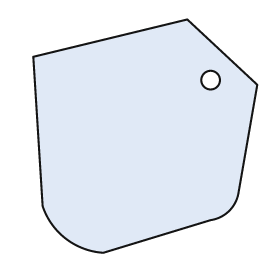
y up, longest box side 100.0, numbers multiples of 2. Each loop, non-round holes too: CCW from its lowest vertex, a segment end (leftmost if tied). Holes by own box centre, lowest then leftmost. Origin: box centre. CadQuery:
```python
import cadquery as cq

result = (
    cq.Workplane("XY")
    .moveTo(-18.0, -50.0)
    .lineTo(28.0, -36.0)
    .threePointArc((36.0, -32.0), (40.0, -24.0))
    .lineTo(48.0, 22.0)
    .lineTo(18.0, 50.0)
    .lineTo(-48.0, 34.0)
    .lineTo(-44.0, -30.0)
    .threePointArc((-34.0, -44.0), (-18.0, -50.0))
    .close()
    .moveTo(28.0, 24.0)
    .circle(4.0)
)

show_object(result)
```